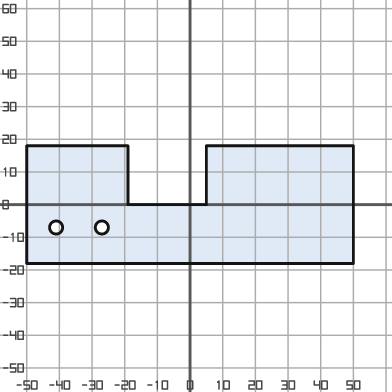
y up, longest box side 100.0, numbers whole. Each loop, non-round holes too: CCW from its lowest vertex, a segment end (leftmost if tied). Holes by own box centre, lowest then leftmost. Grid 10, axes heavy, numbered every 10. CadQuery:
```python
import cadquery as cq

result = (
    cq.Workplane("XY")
    .moveTo(-50.0, -18.0)
    .lineTo(50.0, -18.0)
    .lineTo(50.0, 18.0)
    .lineTo(5.0, 18.0)
    .lineTo(5.0, 0.0)
    .lineTo(-19.0, 0.0)
    .lineTo(-19.0, 18.0)
    .lineTo(-50.0, 18.0)
    .close()
    .moveTo(-41.0, -7.0)
    .circle(2.0)
    .moveTo(-27.0, -7.0)
    .circle(2.0)
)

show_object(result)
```